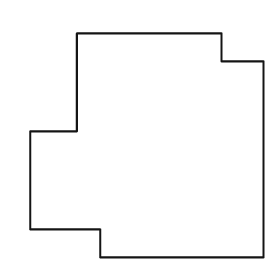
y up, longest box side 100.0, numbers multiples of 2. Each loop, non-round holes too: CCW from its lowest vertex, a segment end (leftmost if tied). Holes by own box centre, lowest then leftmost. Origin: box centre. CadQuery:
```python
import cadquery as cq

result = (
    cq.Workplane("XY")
    .moveTo(-20.0, -48.0)
    .lineTo(50.0, -48.0)
    .lineTo(50.0, 36.0)
    .lineTo(32.0, 36.0)
    .lineTo(32.0, 48.0)
    .lineTo(-30.0, 48.0)
    .lineTo(-30.0, 6.0)
    .lineTo(-50.0, 6.0)
    .lineTo(-50.0, -36.0)
    .lineTo(-20.0, -36.0)
    .close()
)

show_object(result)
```